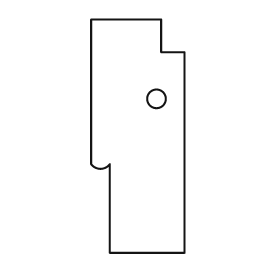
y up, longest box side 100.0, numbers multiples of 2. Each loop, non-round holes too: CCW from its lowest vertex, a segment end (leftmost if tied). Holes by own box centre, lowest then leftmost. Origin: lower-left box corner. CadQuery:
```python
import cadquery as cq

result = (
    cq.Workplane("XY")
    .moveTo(8.0, 0.0)
    .lineTo(40.0, 0.0)
    .lineTo(40.0, 86.0)
    .lineTo(30.0, 86.0)
    .lineTo(30.0, 100.0)
    .lineTo(0.0, 100.0)
    .lineTo(0.0, 38.0)
    .threePointArc((4.0, 36.0), (8.0, 38.0))
    .close()
    .moveTo(28.0, 66.0)
    .circle(4.0)
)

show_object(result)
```